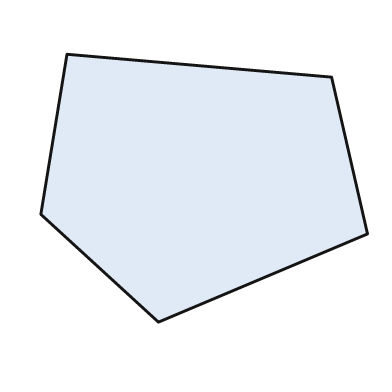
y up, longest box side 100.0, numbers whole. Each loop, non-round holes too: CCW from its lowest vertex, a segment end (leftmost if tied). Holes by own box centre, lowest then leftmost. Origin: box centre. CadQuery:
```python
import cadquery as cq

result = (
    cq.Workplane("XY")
    .moveTo(-14.0, -41.0)
    .lineTo(50.0, -14.0)
    .lineTo(39.0, 34.0)
    .lineTo(-42.0, 41.0)
    .lineTo(-50.0, -8.0)
    .close()
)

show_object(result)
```